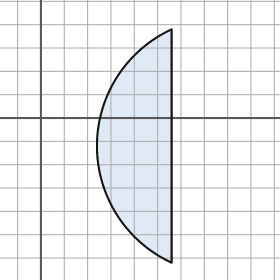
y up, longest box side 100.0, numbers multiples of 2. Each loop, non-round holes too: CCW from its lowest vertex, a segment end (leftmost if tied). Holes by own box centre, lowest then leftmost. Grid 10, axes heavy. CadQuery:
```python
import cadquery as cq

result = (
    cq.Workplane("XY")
    .moveTo(56.0, -62.0)
    .lineTo(56.0, 38.0)
    .threePointArc((24.0, -12.0), (56.0, -62.0))
    .close()
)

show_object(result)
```